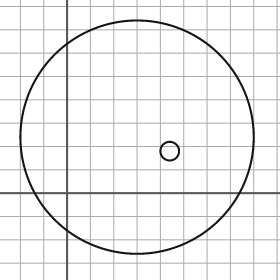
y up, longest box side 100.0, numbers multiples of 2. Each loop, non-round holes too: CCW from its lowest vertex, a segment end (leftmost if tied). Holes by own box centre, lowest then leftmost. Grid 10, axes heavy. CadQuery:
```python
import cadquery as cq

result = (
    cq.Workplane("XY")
    .moveTo(30.0, 24.0)
    .circle(50.0)
    .moveTo(44.0, 18.0)
    .circle(4.0)
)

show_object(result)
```